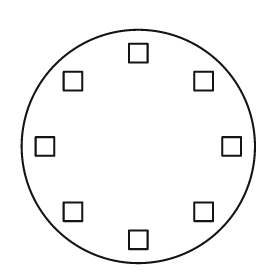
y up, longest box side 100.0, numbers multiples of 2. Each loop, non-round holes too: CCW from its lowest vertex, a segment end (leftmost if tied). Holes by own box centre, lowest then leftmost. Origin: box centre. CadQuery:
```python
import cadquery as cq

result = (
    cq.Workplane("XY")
    .moveTo(0.0, 0.0)
    .circle(50.0)
    .moveTo(-4.0, -44.0)
    .lineTo(4.0, -44.0)
    .lineTo(4.0, -36.0)
    .lineTo(-4.0, -36.0)
    .close()
    .moveTo(-32.0, -32.0)
    .lineTo(-24.0, -32.0)
    .lineTo(-24.0, -24.0)
    .lineTo(-32.0, -24.0)
    .close()
    .moveTo(24.0, -32.0)
    .lineTo(32.0, -32.0)
    .lineTo(32.0, -24.0)
    .lineTo(24.0, -24.0)
    .close()
    .moveTo(-44.0, -4.0)
    .lineTo(-36.0, -4.0)
    .lineTo(-36.0, 4.0)
    .lineTo(-44.0, 4.0)
    .close()
    .moveTo(36.0, -4.0)
    .lineTo(44.0, -4.0)
    .lineTo(44.0, 4.0)
    .lineTo(36.0, 4.0)
    .close()
    .moveTo(-32.0, 24.0)
    .lineTo(-24.0, 24.0)
    .lineTo(-24.0, 32.0)
    .lineTo(-32.0, 32.0)
    .close()
    .moveTo(24.0, 24.0)
    .lineTo(32.0, 24.0)
    .lineTo(32.0, 32.0)
    .lineTo(24.0, 32.0)
    .close()
    .moveTo(-4.0, 36.0)
    .lineTo(4.0, 36.0)
    .lineTo(4.0, 44.0)
    .lineTo(-4.0, 44.0)
    .close()
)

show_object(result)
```